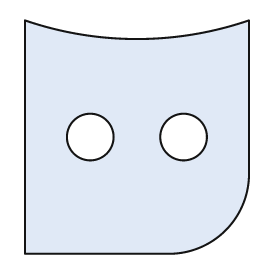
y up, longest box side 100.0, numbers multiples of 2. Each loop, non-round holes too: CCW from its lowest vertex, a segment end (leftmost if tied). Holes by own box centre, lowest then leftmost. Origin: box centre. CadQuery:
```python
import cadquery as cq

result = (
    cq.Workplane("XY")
    .moveTo(-48.0, -50.0)
    .lineTo(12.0, -50.0)
    .threePointArc((38.0, -40.0), (48.0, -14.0))
    .lineTo(48.0, 50.0)
    .threePointArc((0.0, 42.0), (-48.0, 50.0))
    .close()
    .moveTo(-20.0, 0.0)
    .circle(10.0)
    .moveTo(20.0, 0.0)
    .circle(10.0)
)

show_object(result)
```